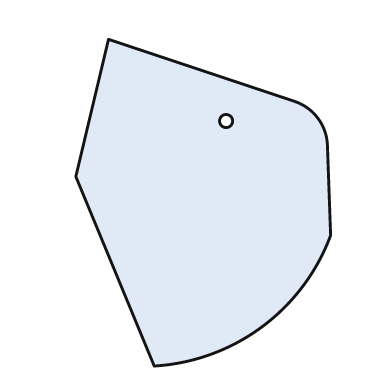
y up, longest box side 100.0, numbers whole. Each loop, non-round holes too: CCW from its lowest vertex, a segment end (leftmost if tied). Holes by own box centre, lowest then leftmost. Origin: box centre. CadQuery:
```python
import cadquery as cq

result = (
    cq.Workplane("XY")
    .moveTo(-15.0, -50.0)
    .threePointArc((18.0, -38.0), (39.0, -10.0))
    .lineTo(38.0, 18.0)
    .threePointArc((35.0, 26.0), (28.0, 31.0))
    .lineTo(-29.0, 50.0)
    .lineTo(-39.0, 8.0)
    .close()
    .moveTo(7.0, 25.0)
    .circle(2.0)
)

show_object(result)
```